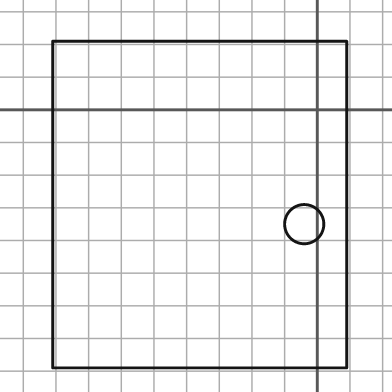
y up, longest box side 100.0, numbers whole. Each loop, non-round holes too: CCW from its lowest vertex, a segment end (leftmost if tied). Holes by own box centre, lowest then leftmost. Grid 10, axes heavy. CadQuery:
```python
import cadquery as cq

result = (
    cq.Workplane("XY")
    .moveTo(-81.0, -79.0)
    .lineTo(9.0, -79.0)
    .lineTo(9.0, 21.0)
    .lineTo(-81.0, 21.0)
    .close()
    .moveTo(-4.0, -35.0)
    .circle(6.0)
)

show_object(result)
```